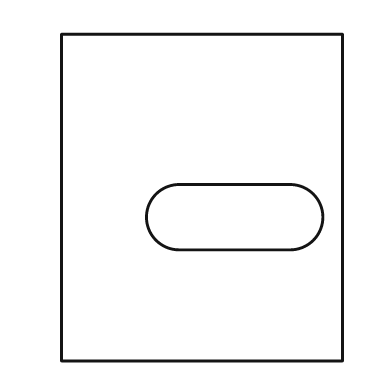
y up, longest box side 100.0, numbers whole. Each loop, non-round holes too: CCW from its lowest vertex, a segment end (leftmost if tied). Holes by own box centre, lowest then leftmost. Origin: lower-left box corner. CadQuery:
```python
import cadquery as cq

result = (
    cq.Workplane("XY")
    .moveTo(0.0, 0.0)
    .lineTo(86.0, 0.0)
    .lineTo(86.0, 100.0)
    .lineTo(0.0, 100.0)
    .close()
    .moveTo(36.0, 34.0)
    .lineTo(70.0, 34.0)
    .threePointArc((80.0, 44.0), (70.0, 54.0))
    .lineTo(36.0, 54.0)
    .threePointArc((26.0, 44.0), (36.0, 34.0))
    .close()
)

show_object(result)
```